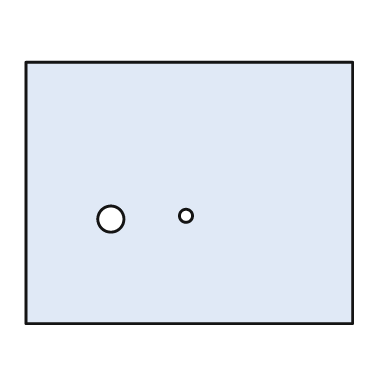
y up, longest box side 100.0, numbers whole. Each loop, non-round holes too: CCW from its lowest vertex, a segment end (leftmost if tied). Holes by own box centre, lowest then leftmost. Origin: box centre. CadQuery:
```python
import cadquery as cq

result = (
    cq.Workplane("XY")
    .moveTo(-50.0, -40.0)
    .lineTo(50.0, -40.0)
    .lineTo(50.0, 40.0)
    .lineTo(-50.0, 40.0)
    .close()
    .moveTo(-24.0, -8.0)
    .circle(4.0)
    .moveTo(-1.0, -7.0)
    .circle(2.0)
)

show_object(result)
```